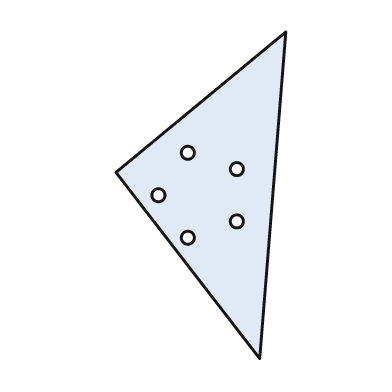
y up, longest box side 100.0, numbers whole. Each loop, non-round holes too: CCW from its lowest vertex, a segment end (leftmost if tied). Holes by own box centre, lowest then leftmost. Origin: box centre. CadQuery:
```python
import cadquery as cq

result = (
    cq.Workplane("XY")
    .moveTo(18.0, -50.0)
    .lineTo(26.0, 50.0)
    .lineTo(-26.0, 7.0)
    .close()
    .moveTo(-4.0, -13.0)
    .circle(2.0)
    .moveTo(11.0, -8.0)
    .circle(2.0)
    .moveTo(-13.0, 0.0)
    .circle(2.0)
    .moveTo(11.0, 8.0)
    .circle(2.0)
    .moveTo(-4.0, 13.0)
    .circle(2.0)
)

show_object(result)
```